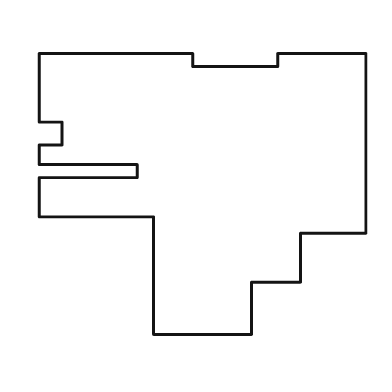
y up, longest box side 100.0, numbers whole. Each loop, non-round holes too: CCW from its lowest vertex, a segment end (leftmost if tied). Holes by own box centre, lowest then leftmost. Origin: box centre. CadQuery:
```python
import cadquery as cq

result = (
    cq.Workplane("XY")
    .moveTo(-15.0, -43.0)
    .lineTo(15.0, -43.0)
    .lineTo(15.0, -27.0)
    .lineTo(30.0, -27.0)
    .lineTo(30.0, -12.0)
    .lineTo(50.0, -12.0)
    .lineTo(50.0, 43.0)
    .lineTo(23.0, 43.0)
    .lineTo(23.0, 39.0)
    .lineTo(-3.0, 39.0)
    .lineTo(-3.0, 43.0)
    .lineTo(-50.0, 43.0)
    .lineTo(-50.0, 22.0)
    .lineTo(-43.0, 22.0)
    .lineTo(-43.0, 15.0)
    .lineTo(-50.0, 15.0)
    .lineTo(-50.0, 9.0)
    .lineTo(-20.0, 9.0)
    .lineTo(-20.0, 5.0)
    .lineTo(-50.0, 5.0)
    .lineTo(-50.0, -7.0)
    .lineTo(-15.0, -7.0)
    .close()
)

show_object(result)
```